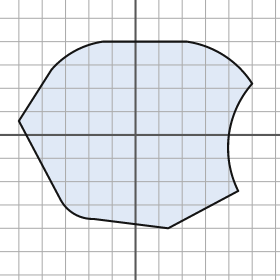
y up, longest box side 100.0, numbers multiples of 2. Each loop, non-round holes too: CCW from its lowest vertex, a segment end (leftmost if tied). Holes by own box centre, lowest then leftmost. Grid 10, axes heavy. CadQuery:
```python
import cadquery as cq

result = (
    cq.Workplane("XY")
    .moveTo(14.0, -40.0)
    .lineTo(44.0, -24.0)
    .threePointArc((40.0, 0.0), (50.0, 22.0))
    .threePointArc((38.0, 34.0), (22.0, 40.0))
    .lineTo(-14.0, 40.0)
    .threePointArc((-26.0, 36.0), (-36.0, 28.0))
    .lineTo(-50.0, 6.0)
    .lineTo(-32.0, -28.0)
    .threePointArc((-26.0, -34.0), (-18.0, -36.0))
    .close()
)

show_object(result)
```